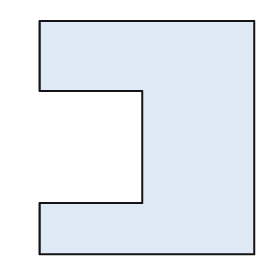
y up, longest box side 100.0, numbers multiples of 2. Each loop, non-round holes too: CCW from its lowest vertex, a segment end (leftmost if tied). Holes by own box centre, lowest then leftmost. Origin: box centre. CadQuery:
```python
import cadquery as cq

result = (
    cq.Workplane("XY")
    .moveTo(-46.0, -50.0)
    .lineTo(46.0, -50.0)
    .lineTo(46.0, 50.0)
    .lineTo(-46.0, 50.0)
    .lineTo(-46.0, 20.0)
    .lineTo(-2.0, 20.0)
    .lineTo(-2.0, -28.0)
    .lineTo(-46.0, -28.0)
    .close()
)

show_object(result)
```